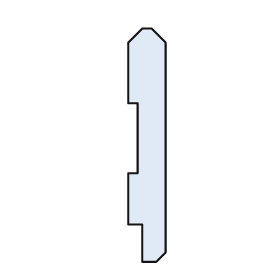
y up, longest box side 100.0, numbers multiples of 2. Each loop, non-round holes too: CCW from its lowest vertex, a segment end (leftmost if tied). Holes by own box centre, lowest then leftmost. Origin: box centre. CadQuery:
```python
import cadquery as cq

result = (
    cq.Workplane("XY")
    .moveTo(-2.0, -50.0)
    .lineTo(4.0, -50.0)
    .lineTo(8.0, -46.0)
    .lineTo(8.0, 44.0)
    .lineTo(2.0, 50.0)
    .lineTo(-2.0, 50.0)
    .lineTo(-8.0, 44.0)
    .lineTo(-8.0, 18.0)
    .lineTo(-4.0, 18.0)
    .lineTo(-4.0, -12.0)
    .lineTo(-8.0, -12.0)
    .lineTo(-8.0, -34.0)
    .lineTo(-2.0, -34.0)
    .close()
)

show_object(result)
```